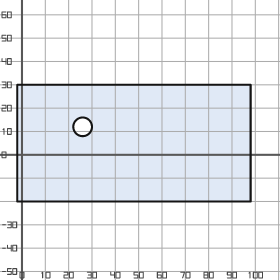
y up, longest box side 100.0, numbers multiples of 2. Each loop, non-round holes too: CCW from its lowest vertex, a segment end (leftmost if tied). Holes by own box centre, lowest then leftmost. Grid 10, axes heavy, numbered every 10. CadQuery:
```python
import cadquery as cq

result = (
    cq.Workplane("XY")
    .moveTo(-2.0, -20.0)
    .lineTo(98.0, -20.0)
    .lineTo(98.0, 30.0)
    .lineTo(-2.0, 30.0)
    .close()
    .moveTo(26.0, 12.0)
    .circle(4.0)
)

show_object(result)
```